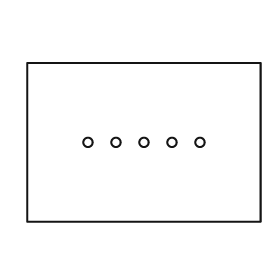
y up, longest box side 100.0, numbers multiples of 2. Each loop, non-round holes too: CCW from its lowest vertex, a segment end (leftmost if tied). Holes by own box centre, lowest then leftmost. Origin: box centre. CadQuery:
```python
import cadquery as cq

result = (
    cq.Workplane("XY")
    .moveTo(-50.0, -34.0)
    .lineTo(50.0, -34.0)
    .lineTo(50.0, 34.0)
    .lineTo(-50.0, 34.0)
    .close()
    .moveTo(-24.0, 0.0)
    .circle(2.0)
    .moveTo(-12.0, 0.0)
    .circle(2.0)
    .moveTo(0.0, 0.0)
    .circle(2.0)
    .moveTo(12.0, 0.0)
    .circle(2.0)
    .moveTo(24.0, 0.0)
    .circle(2.0)
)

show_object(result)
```